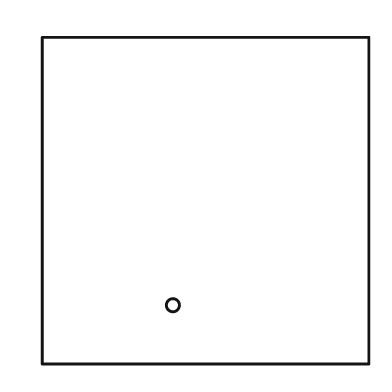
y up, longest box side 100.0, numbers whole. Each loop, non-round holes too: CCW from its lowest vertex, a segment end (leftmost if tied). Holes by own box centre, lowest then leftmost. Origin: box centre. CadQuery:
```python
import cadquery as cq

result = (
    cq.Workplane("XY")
    .moveTo(-50.0, -50.0)
    .lineTo(50.0, -50.0)
    .lineTo(50.0, 50.0)
    .lineTo(-50.0, 50.0)
    .close()
    .moveTo(-10.0, -32.0)
    .circle(2.0)
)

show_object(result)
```